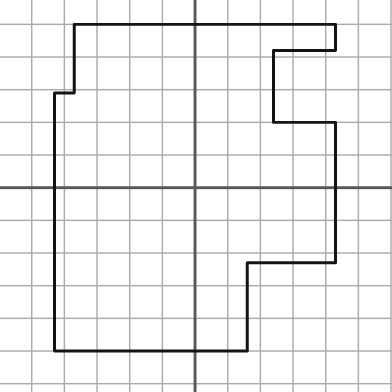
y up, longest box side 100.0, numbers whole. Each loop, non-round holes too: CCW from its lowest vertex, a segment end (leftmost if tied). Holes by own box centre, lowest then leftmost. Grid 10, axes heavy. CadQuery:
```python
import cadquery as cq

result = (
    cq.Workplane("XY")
    .moveTo(-43.0, -50.0)
    .lineTo(16.0, -50.0)
    .lineTo(16.0, -23.0)
    .lineTo(43.0, -23.0)
    .lineTo(43.0, 20.0)
    .lineTo(24.0, 20.0)
    .lineTo(24.0, 42.0)
    .lineTo(43.0, 42.0)
    .lineTo(43.0, 50.0)
    .lineTo(-37.0, 50.0)
    .lineTo(-37.0, 29.0)
    .lineTo(-43.0, 29.0)
    .close()
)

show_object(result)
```